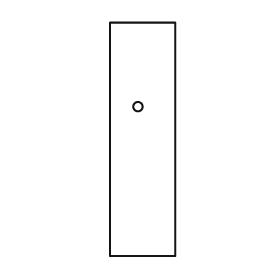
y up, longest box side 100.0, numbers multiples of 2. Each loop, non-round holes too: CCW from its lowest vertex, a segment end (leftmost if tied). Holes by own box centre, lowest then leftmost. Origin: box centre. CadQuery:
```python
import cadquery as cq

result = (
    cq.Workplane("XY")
    .moveTo(-14.0, -50.0)
    .lineTo(14.0, -50.0)
    .lineTo(14.0, 50.0)
    .lineTo(-14.0, 50.0)
    .close()
    .moveTo(-2.0, 14.0)
    .circle(2.0)
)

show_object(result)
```